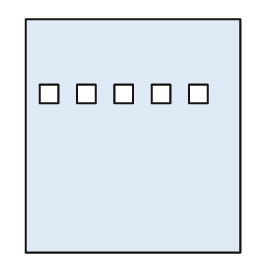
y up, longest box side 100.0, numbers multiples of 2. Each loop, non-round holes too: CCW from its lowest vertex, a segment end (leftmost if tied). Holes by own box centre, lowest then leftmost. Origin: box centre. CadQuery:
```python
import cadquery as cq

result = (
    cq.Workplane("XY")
    .moveTo(-46.0, -50.0)
    .lineTo(46.0, -50.0)
    .lineTo(46.0, 50.0)
    .lineTo(-46.0, 50.0)
    .close()
    .moveTo(-40.0, 14.0)
    .lineTo(-32.0, 14.0)
    .lineTo(-32.0, 22.0)
    .lineTo(-40.0, 22.0)
    .close()
    .moveTo(-24.0, 14.0)
    .lineTo(-16.0, 14.0)
    .lineTo(-16.0, 22.0)
    .lineTo(-24.0, 22.0)
    .close()
    .moveTo(-8.0, 14.0)
    .lineTo(0.0, 14.0)
    .lineTo(0.0, 22.0)
    .lineTo(-8.0, 22.0)
    .close()
    .moveTo(8.0, 14.0)
    .lineTo(16.0, 14.0)
    .lineTo(16.0, 22.0)
    .lineTo(8.0, 22.0)
    .close()
    .moveTo(24.0, 14.0)
    .lineTo(32.0, 14.0)
    .lineTo(32.0, 22.0)
    .lineTo(24.0, 22.0)
    .close()
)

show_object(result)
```